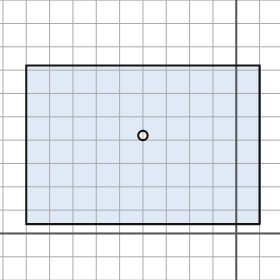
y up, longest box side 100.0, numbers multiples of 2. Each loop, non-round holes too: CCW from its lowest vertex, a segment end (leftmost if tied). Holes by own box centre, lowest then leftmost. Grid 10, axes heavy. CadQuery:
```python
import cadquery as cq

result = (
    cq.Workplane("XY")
    .moveTo(-90.0, 4.0)
    .lineTo(10.0, 4.0)
    .lineTo(10.0, 72.0)
    .lineTo(-90.0, 72.0)
    .close()
    .moveTo(-40.0, 42.0)
    .circle(2.0)
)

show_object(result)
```